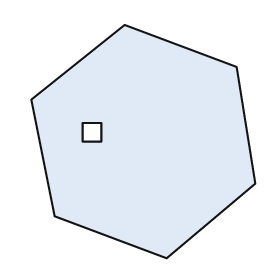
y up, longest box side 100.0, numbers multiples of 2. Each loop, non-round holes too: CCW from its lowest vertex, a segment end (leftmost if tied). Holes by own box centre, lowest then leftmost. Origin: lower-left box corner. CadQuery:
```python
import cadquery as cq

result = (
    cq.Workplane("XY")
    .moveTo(58.0, 0.0)
    .lineTo(96.0, 32.0)
    .lineTo(88.0, 82.0)
    .lineTo(40.0, 100.0)
    .lineTo(0.0, 68.0)
    .lineTo(10.0, 18.0)
    .close()
    .moveTo(22.0, 50.0)
    .lineTo(30.0, 50.0)
    .lineTo(30.0, 58.0)
    .lineTo(22.0, 58.0)
    .close()
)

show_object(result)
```